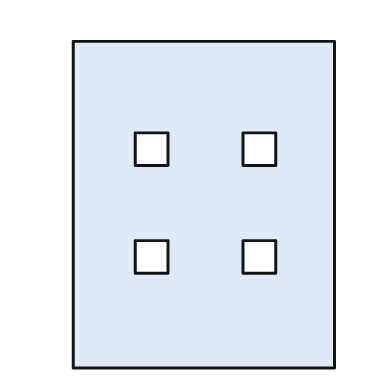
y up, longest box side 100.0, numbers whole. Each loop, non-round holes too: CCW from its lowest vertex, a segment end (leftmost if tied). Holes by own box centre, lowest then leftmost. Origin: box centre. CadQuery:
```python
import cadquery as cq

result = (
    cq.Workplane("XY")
    .moveTo(-40.0, -50.0)
    .lineTo(40.0, -50.0)
    .lineTo(40.0, 50.0)
    .lineTo(-40.0, 50.0)
    .close()
    .moveTo(-21.0, -21.0)
    .lineTo(-11.0, -21.0)
    .lineTo(-11.0, -11.0)
    .lineTo(-21.0, -11.0)
    .close()
    .moveTo(12.0, -21.0)
    .lineTo(22.0, -21.0)
    .lineTo(22.0, -11.0)
    .lineTo(12.0, -11.0)
    .close()
    .moveTo(-21.0, 12.0)
    .lineTo(-11.0, 12.0)
    .lineTo(-11.0, 22.0)
    .lineTo(-21.0, 22.0)
    .close()
    .moveTo(12.0, 12.0)
    .lineTo(22.0, 12.0)
    .lineTo(22.0, 22.0)
    .lineTo(12.0, 22.0)
    .close()
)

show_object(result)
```